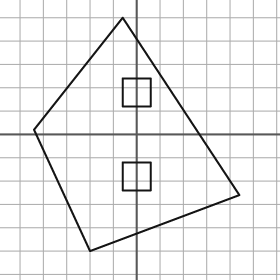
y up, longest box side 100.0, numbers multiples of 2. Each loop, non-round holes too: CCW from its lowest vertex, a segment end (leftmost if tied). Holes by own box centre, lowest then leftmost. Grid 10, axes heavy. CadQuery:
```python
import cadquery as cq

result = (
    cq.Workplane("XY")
    .moveTo(-20.0, -50.0)
    .lineTo(44.0, -26.0)
    .lineTo(-6.0, 50.0)
    .lineTo(-44.0, 2.0)
    .close()
    .moveTo(-6.0, -24.0)
    .lineTo(6.0, -24.0)
    .lineTo(6.0, -12.0)
    .lineTo(-6.0, -12.0)
    .close()
    .moveTo(-6.0, 12.0)
    .lineTo(6.0, 12.0)
    .lineTo(6.0, 24.0)
    .lineTo(-6.0, 24.0)
    .close()
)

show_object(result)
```